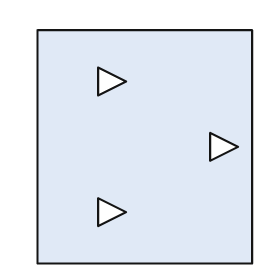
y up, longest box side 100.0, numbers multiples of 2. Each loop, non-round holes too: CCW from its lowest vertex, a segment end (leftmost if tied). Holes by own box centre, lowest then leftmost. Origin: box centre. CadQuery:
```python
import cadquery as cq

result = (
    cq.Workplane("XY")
    .moveTo(-46.0, -50.0)
    .lineTo(46.0, -50.0)
    .lineTo(46.0, 50.0)
    .lineTo(-46.0, 50.0)
    .close()
    .moveTo(-20.0, -34.0)
    .lineTo(-8.0, -28.0)
    .lineTo(-20.0, -22.0)
    .close()
    .moveTo(28.0, -6.0)
    .lineTo(40.0, 0.0)
    .lineTo(28.0, 6.0)
    .close()
    .moveTo(-20.0, 22.0)
    .lineTo(-8.0, 28.0)
    .lineTo(-20.0, 34.0)
    .close()
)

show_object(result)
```